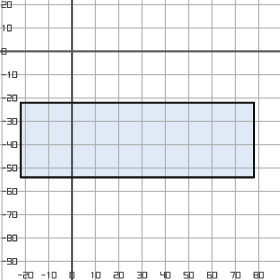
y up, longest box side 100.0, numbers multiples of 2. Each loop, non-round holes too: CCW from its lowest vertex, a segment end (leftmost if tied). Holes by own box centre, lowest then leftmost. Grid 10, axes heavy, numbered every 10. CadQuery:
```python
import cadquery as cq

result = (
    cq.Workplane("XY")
    .moveTo(-22.0, -54.0)
    .lineTo(78.0, -54.0)
    .lineTo(78.0, -22.0)
    .lineTo(-22.0, -22.0)
    .close()
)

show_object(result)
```